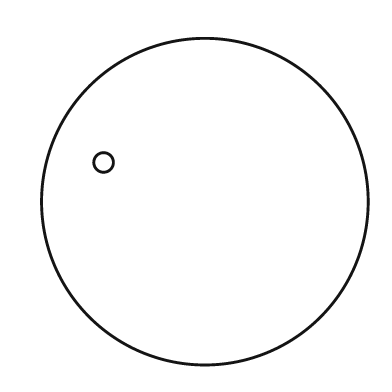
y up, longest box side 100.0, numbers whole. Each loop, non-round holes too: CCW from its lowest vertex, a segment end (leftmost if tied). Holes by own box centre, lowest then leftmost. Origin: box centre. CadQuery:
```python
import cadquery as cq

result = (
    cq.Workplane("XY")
    .moveTo(0.0, 0.0)
    .circle(50.0)
    .moveTo(-31.0, 12.0)
    .circle(3.0)
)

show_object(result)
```